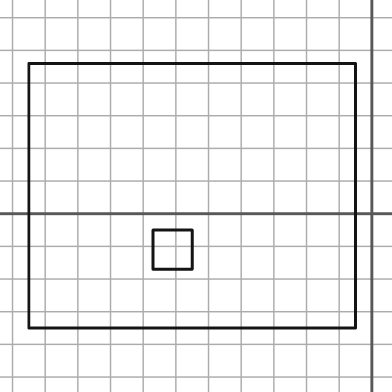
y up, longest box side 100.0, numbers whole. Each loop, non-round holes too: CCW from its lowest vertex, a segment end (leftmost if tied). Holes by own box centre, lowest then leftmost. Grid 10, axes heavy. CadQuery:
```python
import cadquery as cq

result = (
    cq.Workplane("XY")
    .moveTo(-105.0, -35.0)
    .lineTo(-5.0, -35.0)
    .lineTo(-5.0, 46.0)
    .lineTo(-105.0, 46.0)
    .close()
    .moveTo(-67.0, -17.0)
    .lineTo(-55.0, -17.0)
    .lineTo(-55.0, -5.0)
    .lineTo(-67.0, -5.0)
    .close()
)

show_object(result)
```